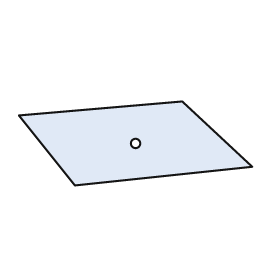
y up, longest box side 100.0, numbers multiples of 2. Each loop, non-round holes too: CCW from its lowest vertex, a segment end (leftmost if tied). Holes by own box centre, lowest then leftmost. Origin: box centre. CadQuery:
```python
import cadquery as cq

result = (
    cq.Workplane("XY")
    .moveTo(-26.0, -18.0)
    .lineTo(50.0, -10.0)
    .lineTo(20.0, 18.0)
    .lineTo(-50.0, 12.0)
    .close()
    .moveTo(0.0, 0.0)
    .circle(2.0)
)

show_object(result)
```